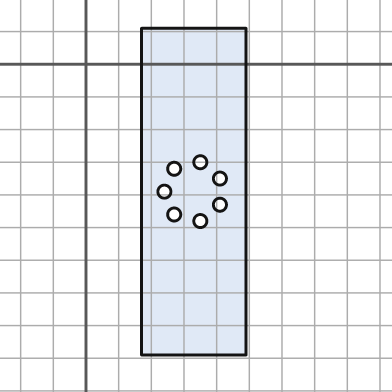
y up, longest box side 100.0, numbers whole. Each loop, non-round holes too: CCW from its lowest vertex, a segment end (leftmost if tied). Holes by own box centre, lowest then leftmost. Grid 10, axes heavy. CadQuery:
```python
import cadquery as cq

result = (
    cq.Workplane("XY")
    .moveTo(17.0, -89.0)
    .lineTo(49.0, -89.0)
    .lineTo(49.0, 11.0)
    .lineTo(17.0, 11.0)
    .close()
    .moveTo(35.0, -48.0)
    .circle(2.0)
    .moveTo(27.0, -46.0)
    .circle(2.0)
    .moveTo(41.0, -43.0)
    .circle(2.0)
    .moveTo(24.0, -39.0)
    .circle(2.0)
    .moveTo(41.0, -35.0)
    .circle(2.0)
    .moveTo(27.0, -32.0)
    .circle(2.0)
    .moveTo(35.0, -30.0)
    .circle(2.0)
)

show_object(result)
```